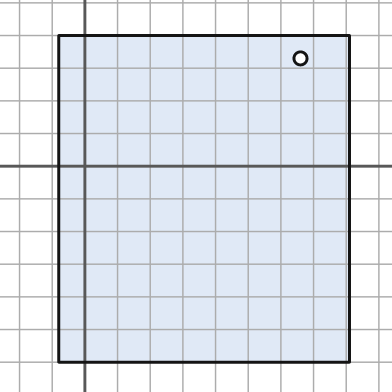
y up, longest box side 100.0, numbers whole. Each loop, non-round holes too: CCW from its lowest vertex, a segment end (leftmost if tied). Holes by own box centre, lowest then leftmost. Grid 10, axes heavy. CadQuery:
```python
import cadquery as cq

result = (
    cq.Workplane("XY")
    .moveTo(-8.0, -60.0)
    .lineTo(81.0, -60.0)
    .lineTo(81.0, 40.0)
    .lineTo(-8.0, 40.0)
    .close()
    .moveTo(66.0, 33.0)
    .circle(2.0)
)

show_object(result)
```